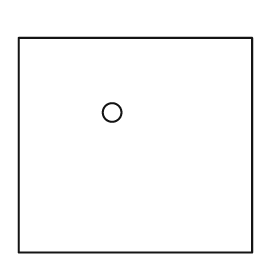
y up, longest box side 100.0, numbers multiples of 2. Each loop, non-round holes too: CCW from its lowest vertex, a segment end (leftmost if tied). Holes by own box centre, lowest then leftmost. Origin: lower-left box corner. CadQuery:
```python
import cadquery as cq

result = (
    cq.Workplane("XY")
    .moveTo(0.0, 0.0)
    .lineTo(100.0, 0.0)
    .lineTo(100.0, 92.0)
    .lineTo(0.0, 92.0)
    .close()
    .moveTo(40.0, 60.0)
    .circle(4.0)
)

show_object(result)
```